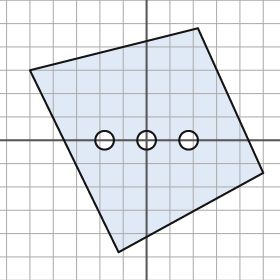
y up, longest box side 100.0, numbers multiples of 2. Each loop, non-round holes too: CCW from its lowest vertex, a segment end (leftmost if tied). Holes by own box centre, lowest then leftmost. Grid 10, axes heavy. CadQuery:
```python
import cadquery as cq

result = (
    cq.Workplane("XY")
    .moveTo(-12.0, -48.0)
    .lineTo(50.0, -14.0)
    .lineTo(22.0, 48.0)
    .lineTo(-50.0, 30.0)
    .close()
    .moveTo(-18.0, 0.0)
    .circle(4.0)
    .moveTo(0.0, 0.0)
    .circle(4.0)
    .moveTo(18.0, 0.0)
    .circle(4.0)
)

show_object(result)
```